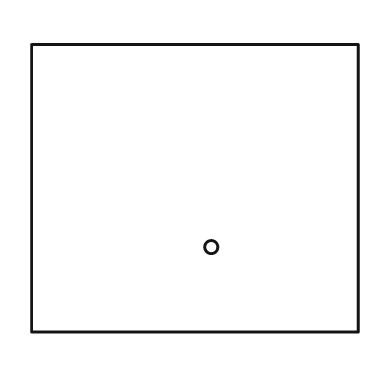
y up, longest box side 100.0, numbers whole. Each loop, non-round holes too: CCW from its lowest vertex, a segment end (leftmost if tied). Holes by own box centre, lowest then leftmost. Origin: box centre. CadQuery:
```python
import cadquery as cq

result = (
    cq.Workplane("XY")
    .moveTo(-50.0, -44.0)
    .lineTo(50.0, -44.0)
    .lineTo(50.0, 44.0)
    .lineTo(-50.0, 44.0)
    .close()
    .moveTo(5.0, -18.0)
    .circle(2.0)
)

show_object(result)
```